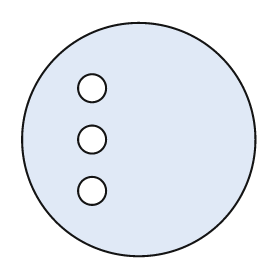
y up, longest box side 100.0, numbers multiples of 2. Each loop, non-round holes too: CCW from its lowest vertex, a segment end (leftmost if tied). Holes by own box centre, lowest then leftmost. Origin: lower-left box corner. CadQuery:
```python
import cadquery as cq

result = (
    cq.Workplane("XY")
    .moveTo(50.0, 50.0)
    .circle(50.0)
    .moveTo(30.0, 28.0)
    .circle(6.0)
    .moveTo(30.0, 50.0)
    .circle(6.0)
    .moveTo(30.0, 72.0)
    .circle(6.0)
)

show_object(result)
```